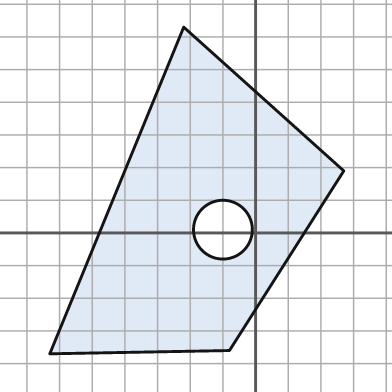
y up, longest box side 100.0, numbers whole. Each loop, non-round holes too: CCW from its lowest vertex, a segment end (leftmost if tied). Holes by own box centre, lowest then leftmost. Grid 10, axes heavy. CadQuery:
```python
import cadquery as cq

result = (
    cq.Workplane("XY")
    .moveTo(-63.0, -37.0)
    .lineTo(-8.0, -36.0)
    .lineTo(27.0, 19.0)
    .lineTo(-22.0, 63.0)
    .close()
    .moveTo(-10.0, 1.0)
    .circle(9.0)
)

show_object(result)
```